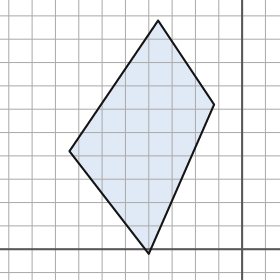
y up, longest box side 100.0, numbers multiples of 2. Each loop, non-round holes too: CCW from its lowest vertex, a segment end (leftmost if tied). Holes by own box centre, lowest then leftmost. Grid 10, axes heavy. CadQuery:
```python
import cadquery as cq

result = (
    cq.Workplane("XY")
    .moveTo(-40.0, -2.0)
    .lineTo(-12.0, 62.0)
    .lineTo(-36.0, 98.0)
    .lineTo(-74.0, 42.0)
    .close()
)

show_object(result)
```